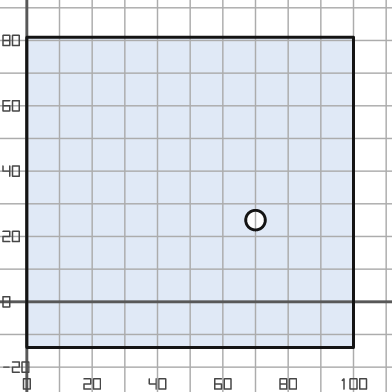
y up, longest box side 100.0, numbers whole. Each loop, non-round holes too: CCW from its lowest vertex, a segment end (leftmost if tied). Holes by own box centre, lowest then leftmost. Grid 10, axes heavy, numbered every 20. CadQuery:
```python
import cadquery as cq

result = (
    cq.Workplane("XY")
    .moveTo(0.0, -14.0)
    .lineTo(100.0, -14.0)
    .lineTo(100.0, 81.0)
    .lineTo(0.0, 81.0)
    .close()
    .moveTo(70.0, 25.0)
    .circle(3.0)
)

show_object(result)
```